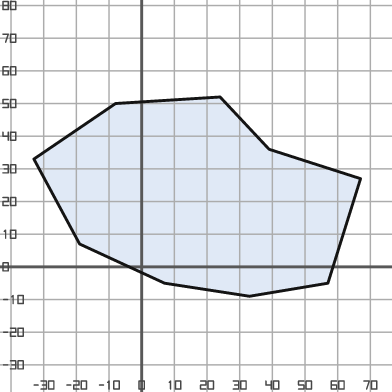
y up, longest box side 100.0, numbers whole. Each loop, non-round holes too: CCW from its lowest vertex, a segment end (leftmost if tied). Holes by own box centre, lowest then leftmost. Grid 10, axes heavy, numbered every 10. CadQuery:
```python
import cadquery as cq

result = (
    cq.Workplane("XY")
    .moveTo(33.0, -9.0)
    .lineTo(57.0, -5.0)
    .lineTo(67.0, 27.0)
    .lineTo(39.0, 36.0)
    .lineTo(24.0, 52.0)
    .lineTo(-8.0, 50.0)
    .lineTo(-33.0, 33.0)
    .lineTo(-19.0, 7.0)
    .lineTo(7.0, -5.0)
    .close()
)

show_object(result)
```